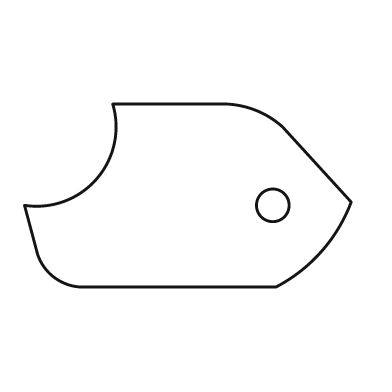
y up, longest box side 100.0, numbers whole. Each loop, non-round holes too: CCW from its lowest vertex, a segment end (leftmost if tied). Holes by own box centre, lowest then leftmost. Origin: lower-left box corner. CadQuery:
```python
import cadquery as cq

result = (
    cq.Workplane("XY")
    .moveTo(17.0, 0.0)
    .lineTo(77.0, 0.0)
    .threePointArc((91.0, 11.0), (100.0, 26.0))
    .lineTo(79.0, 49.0)
    .threePointArc((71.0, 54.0), (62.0, 56.0))
    .lineTo(27.0, 56.0)
    .threePointArc((22.0, 33.0), (0.0, 25.0))
    .lineTo(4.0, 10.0)
    .threePointArc((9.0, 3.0), (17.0, 0.0))
    .close()
    .moveTo(76.0, 25.0)
    .circle(5.0)
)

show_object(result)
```